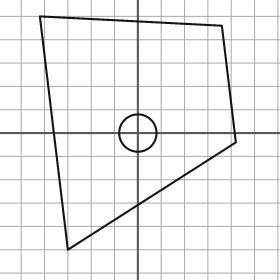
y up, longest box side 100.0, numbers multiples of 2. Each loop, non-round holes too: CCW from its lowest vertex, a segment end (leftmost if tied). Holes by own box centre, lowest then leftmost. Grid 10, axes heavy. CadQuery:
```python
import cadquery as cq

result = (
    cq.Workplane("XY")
    .moveTo(-30.0, -50.0)
    .lineTo(42.0, -4.0)
    .lineTo(36.0, 46.0)
    .lineTo(-42.0, 50.0)
    .close()
    .moveTo(0.0, 0.0)
    .circle(8.0)
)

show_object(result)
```